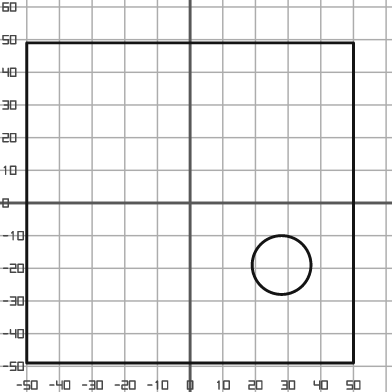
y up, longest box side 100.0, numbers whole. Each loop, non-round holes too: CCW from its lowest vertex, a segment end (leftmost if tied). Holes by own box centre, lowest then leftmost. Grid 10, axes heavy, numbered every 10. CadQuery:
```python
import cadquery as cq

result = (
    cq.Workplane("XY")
    .moveTo(-50.0, -49.0)
    .lineTo(50.0, -49.0)
    .lineTo(50.0, 49.0)
    .lineTo(-50.0, 49.0)
    .close()
    .moveTo(28.0, -19.0)
    .circle(9.0)
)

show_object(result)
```